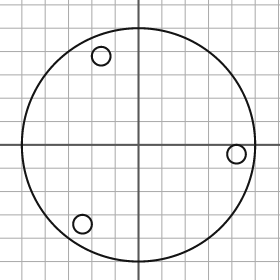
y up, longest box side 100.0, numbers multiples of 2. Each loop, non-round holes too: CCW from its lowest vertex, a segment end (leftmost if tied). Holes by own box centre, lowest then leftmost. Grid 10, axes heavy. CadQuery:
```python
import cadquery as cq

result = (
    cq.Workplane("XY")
    .moveTo(0.0, 0.0)
    .circle(50.0)
    .moveTo(-24.0, -34.0)
    .circle(4.0)
    .moveTo(42.0, -4.0)
    .circle(4.0)
    .moveTo(-16.0, 38.0)
    .circle(4.0)
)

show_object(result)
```